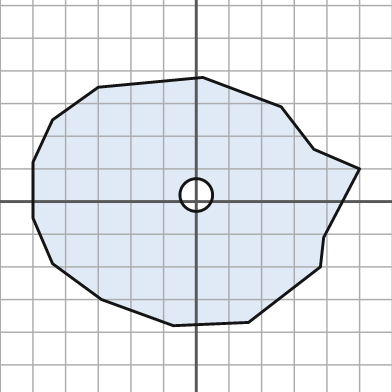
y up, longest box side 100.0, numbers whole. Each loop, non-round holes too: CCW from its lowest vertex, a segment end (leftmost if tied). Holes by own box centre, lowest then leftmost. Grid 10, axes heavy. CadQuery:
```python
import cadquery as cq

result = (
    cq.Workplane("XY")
    .moveTo(-7.0, -38.0)
    .lineTo(16.0, -37.0)
    .lineTo(38.0, -20.0)
    .lineTo(39.0, -11.0)
    .lineTo(50.0, 10.0)
    .lineTo(36.0, 16.0)
    .lineTo(26.0, 29.0)
    .lineTo(2.0, 38.0)
    .lineTo(-30.0, 35.0)
    .lineTo(-44.0, 25.0)
    .lineTo(-50.0, 12.0)
    .lineTo(-50.0, -5.0)
    .lineTo(-44.0, -19.0)
    .lineTo(-29.0, -30.0)
    .close()
    .moveTo(0.0, 2.0)
    .circle(5.0)
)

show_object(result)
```